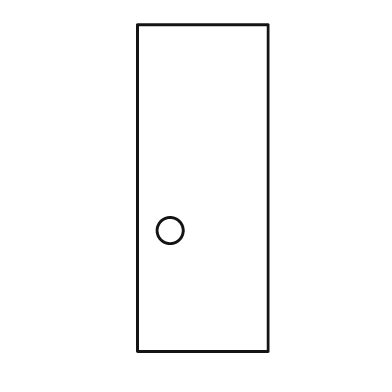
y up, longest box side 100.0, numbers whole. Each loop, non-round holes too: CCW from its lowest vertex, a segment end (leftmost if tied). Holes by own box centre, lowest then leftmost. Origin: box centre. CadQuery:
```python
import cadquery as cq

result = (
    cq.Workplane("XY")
    .moveTo(-20.0, -50.0)
    .lineTo(20.0, -50.0)
    .lineTo(20.0, 50.0)
    .lineTo(-20.0, 50.0)
    .close()
    .moveTo(-10.0, -13.0)
    .circle(4.0)
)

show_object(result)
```